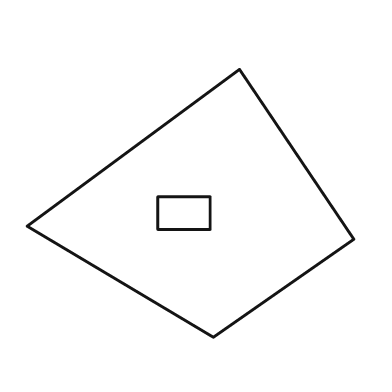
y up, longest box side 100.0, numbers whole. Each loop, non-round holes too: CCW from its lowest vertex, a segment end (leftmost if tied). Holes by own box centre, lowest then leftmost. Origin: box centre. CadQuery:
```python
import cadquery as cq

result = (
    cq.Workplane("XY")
    .moveTo(7.0, -41.0)
    .lineTo(50.0, -11.0)
    .lineTo(15.0, 41.0)
    .lineTo(-50.0, -7.0)
    .close()
    .moveTo(-10.0, -8.0)
    .lineTo(6.0, -8.0)
    .lineTo(6.0, 2.0)
    .lineTo(-10.0, 2.0)
    .close()
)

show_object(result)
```